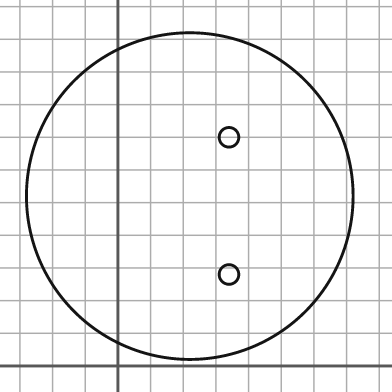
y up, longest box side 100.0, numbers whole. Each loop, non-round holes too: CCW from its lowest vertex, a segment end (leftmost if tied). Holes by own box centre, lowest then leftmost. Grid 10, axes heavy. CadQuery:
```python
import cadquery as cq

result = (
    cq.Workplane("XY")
    .moveTo(22.0, 52.0)
    .circle(50.0)
    .moveTo(34.0, 28.0)
    .circle(3.0)
    .moveTo(34.0, 70.0)
    .circle(3.0)
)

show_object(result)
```